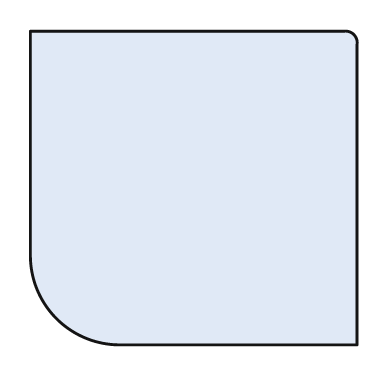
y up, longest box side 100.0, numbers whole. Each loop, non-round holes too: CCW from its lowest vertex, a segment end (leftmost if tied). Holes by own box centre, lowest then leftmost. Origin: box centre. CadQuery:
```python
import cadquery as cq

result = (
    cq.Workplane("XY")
    .moveTo(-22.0, -48.0)
    .lineTo(50.0, -48.0)
    .lineTo(50.0, 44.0)
    .threePointArc((49.0, 47.0), (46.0, 48.0))
    .lineTo(-50.0, 48.0)
    .lineTo(-50.0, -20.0)
    .threePointArc((-42.0, -40.0), (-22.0, -48.0))
    .close()
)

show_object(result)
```